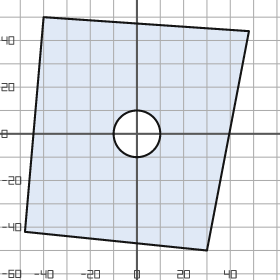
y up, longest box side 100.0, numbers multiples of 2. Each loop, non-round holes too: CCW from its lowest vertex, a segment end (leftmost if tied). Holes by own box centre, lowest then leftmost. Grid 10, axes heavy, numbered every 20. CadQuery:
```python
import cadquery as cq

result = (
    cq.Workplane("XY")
    .moveTo(30.0, -50.0)
    .lineTo(48.0, 44.0)
    .lineTo(-40.0, 50.0)
    .lineTo(-48.0, -42.0)
    .close()
    .moveTo(0.0, 0.0)
    .circle(10.0)
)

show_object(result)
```